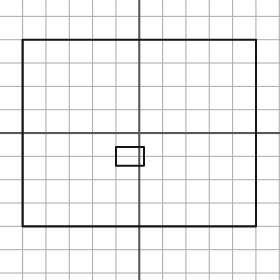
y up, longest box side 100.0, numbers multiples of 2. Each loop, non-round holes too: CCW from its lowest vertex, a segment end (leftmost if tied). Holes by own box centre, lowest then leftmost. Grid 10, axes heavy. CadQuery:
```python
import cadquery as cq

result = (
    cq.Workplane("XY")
    .moveTo(-50.0, -40.0)
    .lineTo(50.0, -40.0)
    .lineTo(50.0, 40.0)
    .lineTo(-50.0, 40.0)
    .close()
    .moveTo(-10.0, -14.0)
    .lineTo(2.0, -14.0)
    .lineTo(2.0, -6.0)
    .lineTo(-10.0, -6.0)
    .close()
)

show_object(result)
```